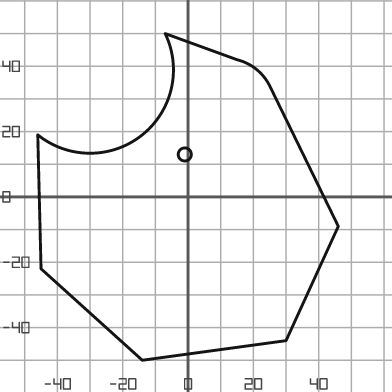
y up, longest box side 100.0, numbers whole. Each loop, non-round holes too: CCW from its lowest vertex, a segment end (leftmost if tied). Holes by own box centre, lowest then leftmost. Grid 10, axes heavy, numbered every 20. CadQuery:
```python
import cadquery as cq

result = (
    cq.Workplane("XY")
    .moveTo(-14.0, -50.0)
    .lineTo(30.0, -44.0)
    .lineTo(46.0, -9.0)
    .lineTo(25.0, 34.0)
    .threePointArc((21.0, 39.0), (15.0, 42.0))
    .lineTo(-7.0, 50.0)
    .threePointArc((-14.0, 19.0), (-46.0, 19.0))
    .lineTo(-45.0, -22.0)
    .close()
    .moveTo(-1.0, 13.0)
    .circle(2.0)
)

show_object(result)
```